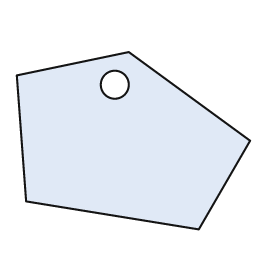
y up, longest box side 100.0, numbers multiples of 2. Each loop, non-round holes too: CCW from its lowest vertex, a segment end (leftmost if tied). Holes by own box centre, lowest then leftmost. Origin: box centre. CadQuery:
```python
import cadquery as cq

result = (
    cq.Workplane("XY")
    .moveTo(28.0, -38.0)
    .lineTo(50.0, 0.0)
    .lineTo(-2.0, 38.0)
    .lineTo(-50.0, 28.0)
    .lineTo(-46.0, -26.0)
    .close()
    .moveTo(-8.0, 24.0)
    .circle(6.0)
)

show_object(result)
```